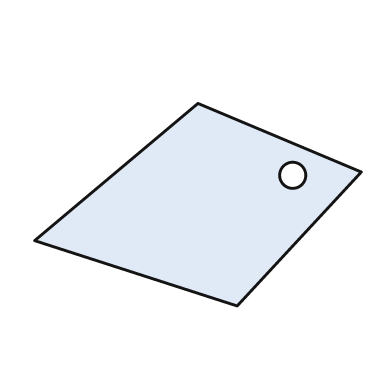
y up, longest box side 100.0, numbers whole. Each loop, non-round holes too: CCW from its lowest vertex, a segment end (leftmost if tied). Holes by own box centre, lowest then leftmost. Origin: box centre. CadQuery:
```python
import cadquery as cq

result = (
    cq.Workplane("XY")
    .moveTo(12.0, -31.0)
    .lineTo(50.0, 10.0)
    .lineTo(0.0, 31.0)
    .lineTo(-50.0, -11.0)
    .close()
    .moveTo(29.0, 9.0)
    .circle(4.0)
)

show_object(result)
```